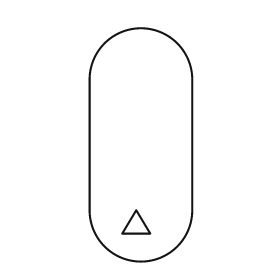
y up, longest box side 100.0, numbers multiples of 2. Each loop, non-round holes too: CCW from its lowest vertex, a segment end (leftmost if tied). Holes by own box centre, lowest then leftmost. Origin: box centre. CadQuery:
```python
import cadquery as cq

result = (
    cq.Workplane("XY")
    .moveTo(-22.0, -28.0)
    .threePointArc((0.0, -50.0), (22.0, -28.0))
    .lineTo(22.0, 28.0)
    .threePointArc((0.0, 50.0), (-22.0, 28.0))
    .close()
    .moveTo(-8.0, -38.0)
    .lineTo(4.0, -38.0)
    .lineTo(-2.0, -28.0)
    .close()
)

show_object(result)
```